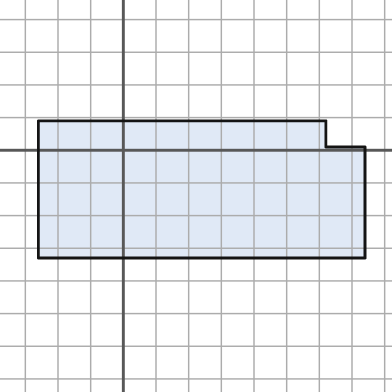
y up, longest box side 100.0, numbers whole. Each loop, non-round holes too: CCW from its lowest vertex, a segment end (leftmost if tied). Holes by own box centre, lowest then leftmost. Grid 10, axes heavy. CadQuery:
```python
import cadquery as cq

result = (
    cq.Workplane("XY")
    .moveTo(-26.0, -33.0)
    .lineTo(74.0, -33.0)
    .lineTo(74.0, 1.0)
    .lineTo(62.0, 1.0)
    .lineTo(62.0, 9.0)
    .lineTo(-26.0, 9.0)
    .close()
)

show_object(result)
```